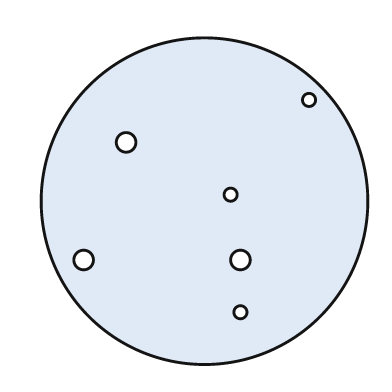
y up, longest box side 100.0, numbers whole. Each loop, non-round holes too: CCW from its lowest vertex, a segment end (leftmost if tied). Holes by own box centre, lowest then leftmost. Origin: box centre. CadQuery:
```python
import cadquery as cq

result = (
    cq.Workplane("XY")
    .moveTo(0.0, 0.0)
    .circle(50.0)
    .moveTo(11.0, -34.0)
    .circle(2.0)
    .moveTo(-37.0, -18.0)
    .circle(3.0)
    .moveTo(11.0, -18.0)
    .circle(3.0)
    .moveTo(8.0, 2.0)
    .circle(2.0)
    .moveTo(-24.0, 18.0)
    .circle(3.0)
    .moveTo(32.0, 31.0)
    .circle(2.0)
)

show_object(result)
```